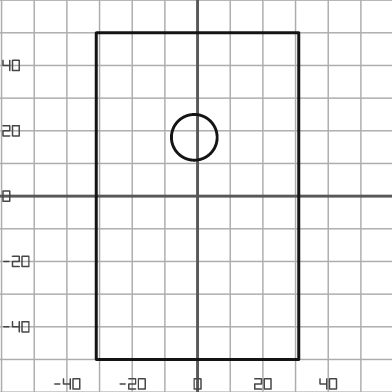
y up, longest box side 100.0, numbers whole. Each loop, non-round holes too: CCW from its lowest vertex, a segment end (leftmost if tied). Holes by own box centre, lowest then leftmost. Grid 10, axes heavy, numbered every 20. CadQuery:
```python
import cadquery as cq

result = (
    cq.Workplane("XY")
    .moveTo(-31.0, -50.0)
    .lineTo(31.0, -50.0)
    .lineTo(31.0, 50.0)
    .lineTo(-31.0, 50.0)
    .close()
    .moveTo(-1.0, 18.0)
    .circle(7.0)
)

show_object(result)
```